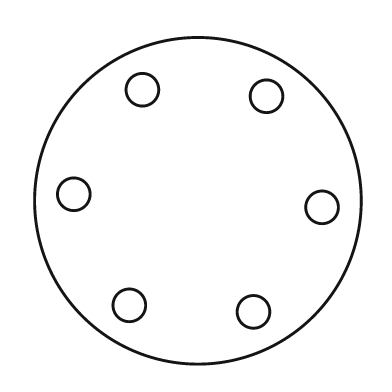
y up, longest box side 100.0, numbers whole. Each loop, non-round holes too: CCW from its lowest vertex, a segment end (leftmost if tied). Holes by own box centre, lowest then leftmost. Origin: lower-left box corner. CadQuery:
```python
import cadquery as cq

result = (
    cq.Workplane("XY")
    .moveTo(50.0, 50.0)
    .circle(50.0)
    .moveTo(67.0, 16.0)
    .circle(5.0)
    .moveTo(29.0, 18.0)
    .circle(5.0)
    .moveTo(88.0, 48.0)
    .circle(5.0)
    .moveTo(12.0, 52.0)
    .circle(5.0)
    .moveTo(71.0, 82.0)
    .circle(5.0)
    .moveTo(33.0, 84.0)
    .circle(5.0)
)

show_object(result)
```